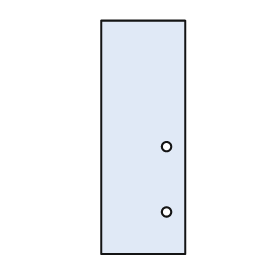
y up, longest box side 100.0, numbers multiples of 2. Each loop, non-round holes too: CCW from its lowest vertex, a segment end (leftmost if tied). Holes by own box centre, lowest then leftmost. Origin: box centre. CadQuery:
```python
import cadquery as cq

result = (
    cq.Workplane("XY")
    .moveTo(-18.0, -50.0)
    .lineTo(18.0, -50.0)
    .lineTo(18.0, 50.0)
    .lineTo(-18.0, 50.0)
    .close()
    .moveTo(10.0, -32.0)
    .circle(2.0)
    .moveTo(10.0, -4.0)
    .circle(2.0)
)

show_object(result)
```